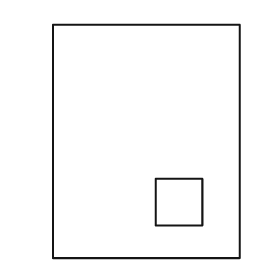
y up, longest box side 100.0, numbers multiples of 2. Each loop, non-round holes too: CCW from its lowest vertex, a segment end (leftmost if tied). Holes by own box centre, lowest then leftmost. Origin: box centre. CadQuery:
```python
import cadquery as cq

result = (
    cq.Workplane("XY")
    .moveTo(-40.0, -50.0)
    .lineTo(40.0, -50.0)
    .lineTo(40.0, 50.0)
    .lineTo(-40.0, 50.0)
    .close()
    .moveTo(4.0, -36.0)
    .lineTo(24.0, -36.0)
    .lineTo(24.0, -16.0)
    .lineTo(4.0, -16.0)
    .close()
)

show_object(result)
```